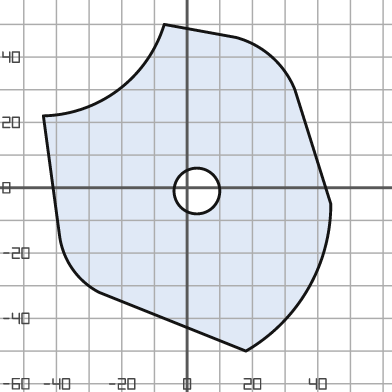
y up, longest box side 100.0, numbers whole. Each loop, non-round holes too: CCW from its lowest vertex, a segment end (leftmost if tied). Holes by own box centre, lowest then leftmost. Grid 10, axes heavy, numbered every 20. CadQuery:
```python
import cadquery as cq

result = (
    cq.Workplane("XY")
    .moveTo(18.0, -50.0)
    .threePointArc((37.0, -31.0), (44.0, -5.0))
    .lineTo(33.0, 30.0)
    .threePointArc((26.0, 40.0), (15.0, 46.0))
    .lineTo(-7.0, 50.0)
    .threePointArc((-21.0, 30.0), (-44.0, 22.0))
    .lineTo(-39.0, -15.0)
    .threePointArc((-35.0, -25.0), (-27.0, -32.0))
    .close()
    .moveTo(3.0, -1.0)
    .circle(7.0)
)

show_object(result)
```